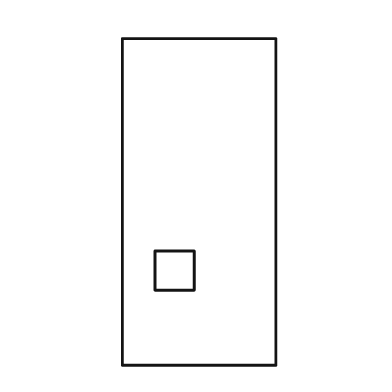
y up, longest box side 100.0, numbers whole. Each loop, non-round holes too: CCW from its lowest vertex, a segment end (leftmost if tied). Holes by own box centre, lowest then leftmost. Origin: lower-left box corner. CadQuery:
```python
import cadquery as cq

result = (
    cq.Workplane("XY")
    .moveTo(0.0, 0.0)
    .lineTo(47.0, 0.0)
    .lineTo(47.0, 100.0)
    .lineTo(0.0, 100.0)
    .close()
    .moveTo(10.0, 23.0)
    .lineTo(22.0, 23.0)
    .lineTo(22.0, 35.0)
    .lineTo(10.0, 35.0)
    .close()
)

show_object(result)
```